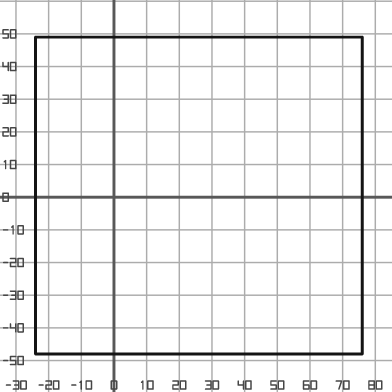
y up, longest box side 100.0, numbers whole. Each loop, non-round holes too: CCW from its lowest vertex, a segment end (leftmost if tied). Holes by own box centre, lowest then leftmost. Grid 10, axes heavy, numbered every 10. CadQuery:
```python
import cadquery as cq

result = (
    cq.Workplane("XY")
    .moveTo(-24.0, -48.0)
    .lineTo(76.0, -48.0)
    .lineTo(76.0, 49.0)
    .lineTo(-24.0, 49.0)
    .close()
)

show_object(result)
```